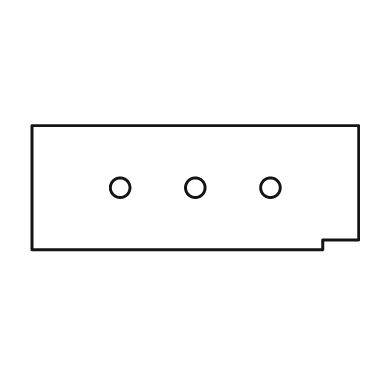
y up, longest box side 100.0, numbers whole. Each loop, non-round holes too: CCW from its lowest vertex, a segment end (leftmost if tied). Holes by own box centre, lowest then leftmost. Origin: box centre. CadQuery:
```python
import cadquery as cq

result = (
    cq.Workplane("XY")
    .moveTo(-50.0, -19.0)
    .lineTo(39.0, -19.0)
    .lineTo(39.0, -16.0)
    .lineTo(50.0, -16.0)
    .lineTo(50.0, 19.0)
    .lineTo(-50.0, 19.0)
    .close()
    .moveTo(-23.0, 0.0)
    .circle(3.0)
    .moveTo(0.0, 0.0)
    .circle(3.0)
    .moveTo(23.0, 0.0)
    .circle(3.0)
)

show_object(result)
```